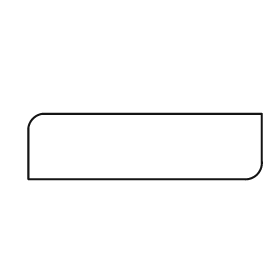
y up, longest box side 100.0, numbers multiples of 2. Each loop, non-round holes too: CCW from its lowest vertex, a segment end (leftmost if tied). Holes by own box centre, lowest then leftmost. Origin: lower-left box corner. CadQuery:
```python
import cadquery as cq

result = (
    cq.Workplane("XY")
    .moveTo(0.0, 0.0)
    .lineTo(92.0, 0.0)
    .threePointArc((98.0, 2.0), (100.0, 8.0))
    .lineTo(100.0, 28.0)
    .lineTo(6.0, 28.0)
    .threePointArc((2.0, 26.0), (0.0, 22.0))
    .close()
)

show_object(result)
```